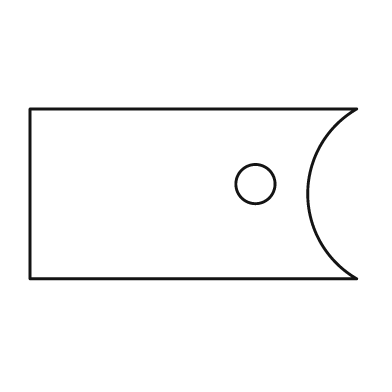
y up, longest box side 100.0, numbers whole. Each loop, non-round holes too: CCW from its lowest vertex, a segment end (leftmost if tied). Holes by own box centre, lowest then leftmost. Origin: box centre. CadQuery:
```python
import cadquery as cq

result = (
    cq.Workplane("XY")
    .moveTo(-50.0, -26.0)
    .lineTo(50.0, -26.0)
    .threePointArc((35.0, 0.0), (50.0, 26.0))
    .lineTo(-50.0, 26.0)
    .close()
    .moveTo(19.0, 3.0)
    .circle(6.0)
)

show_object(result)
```